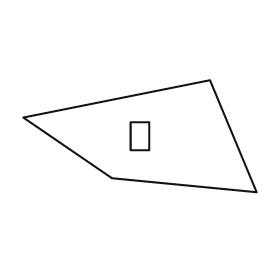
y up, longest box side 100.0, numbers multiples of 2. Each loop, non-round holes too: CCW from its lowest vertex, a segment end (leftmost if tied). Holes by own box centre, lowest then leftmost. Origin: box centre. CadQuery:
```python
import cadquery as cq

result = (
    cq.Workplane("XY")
    .moveTo(50.0, -24.0)
    .lineTo(30.0, 24.0)
    .lineTo(-50.0, 8.0)
    .lineTo(-12.0, -18.0)
    .close()
    .moveTo(-4.0, -6.0)
    .lineTo(4.0, -6.0)
    .lineTo(4.0, 6.0)
    .lineTo(-4.0, 6.0)
    .close()
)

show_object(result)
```